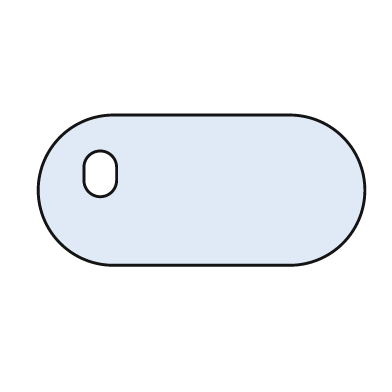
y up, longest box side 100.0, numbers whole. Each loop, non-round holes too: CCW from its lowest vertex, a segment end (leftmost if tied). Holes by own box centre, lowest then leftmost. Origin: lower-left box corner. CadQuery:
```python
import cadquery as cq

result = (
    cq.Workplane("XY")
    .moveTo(23.0, 0.0)
    .lineTo(77.0, 0.0)
    .threePointArc((100.0, 23.0), (77.0, 46.0))
    .lineTo(23.0, 46.0)
    .threePointArc((0.0, 23.0), (23.0, 0.0))
    .close()
    .moveTo(14.0, 26.0)
    .threePointArc((19.0, 21.0), (24.0, 26.0))
    .lineTo(24.0, 30.0)
    .threePointArc((19.0, 35.0), (14.0, 30.0))
    .close()
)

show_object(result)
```